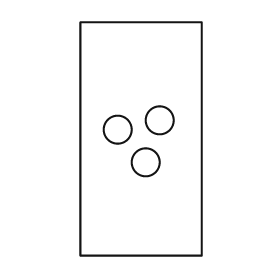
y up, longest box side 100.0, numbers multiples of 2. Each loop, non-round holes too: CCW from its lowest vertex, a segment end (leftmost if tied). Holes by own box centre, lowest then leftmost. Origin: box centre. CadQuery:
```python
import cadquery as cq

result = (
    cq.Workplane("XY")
    .moveTo(-26.0, -50.0)
    .lineTo(26.0, -50.0)
    .lineTo(26.0, 50.0)
    .lineTo(-26.0, 50.0)
    .close()
    .moveTo(2.0, -10.0)
    .circle(6.0)
    .moveTo(-10.0, 4.0)
    .circle(6.0)
    .moveTo(8.0, 8.0)
    .circle(6.0)
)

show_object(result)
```